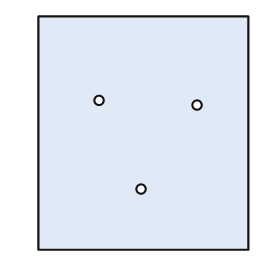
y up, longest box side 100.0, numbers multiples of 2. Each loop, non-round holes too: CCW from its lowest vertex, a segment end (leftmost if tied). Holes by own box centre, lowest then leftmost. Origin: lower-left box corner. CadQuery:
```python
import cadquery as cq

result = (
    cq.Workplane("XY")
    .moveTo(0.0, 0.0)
    .lineTo(90.0, 0.0)
    .lineTo(90.0, 100.0)
    .lineTo(0.0, 100.0)
    .close()
    .moveTo(44.0, 26.0)
    .circle(2.0)
    .moveTo(68.0, 62.0)
    .circle(2.0)
    .moveTo(26.0, 64.0)
    .circle(2.0)
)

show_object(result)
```